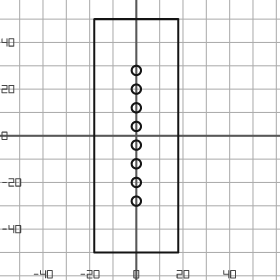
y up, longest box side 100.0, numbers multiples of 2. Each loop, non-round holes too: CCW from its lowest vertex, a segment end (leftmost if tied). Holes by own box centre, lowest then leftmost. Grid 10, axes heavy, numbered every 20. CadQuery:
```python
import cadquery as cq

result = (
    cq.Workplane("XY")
    .moveTo(-18.0, -50.0)
    .lineTo(18.0, -50.0)
    .lineTo(18.0, 50.0)
    .lineTo(-18.0, 50.0)
    .close()
    .moveTo(0.0, -28.0)
    .circle(2.0)
    .moveTo(0.0, -20.0)
    .circle(2.0)
    .moveTo(0.0, -12.0)
    .circle(2.0)
    .moveTo(0.0, -4.0)
    .circle(2.0)
    .moveTo(0.0, 4.0)
    .circle(2.0)
    .moveTo(0.0, 12.0)
    .circle(2.0)
    .moveTo(0.0, 20.0)
    .circle(2.0)
    .moveTo(0.0, 28.0)
    .circle(2.0)
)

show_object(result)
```